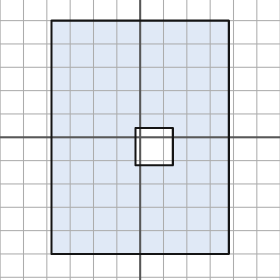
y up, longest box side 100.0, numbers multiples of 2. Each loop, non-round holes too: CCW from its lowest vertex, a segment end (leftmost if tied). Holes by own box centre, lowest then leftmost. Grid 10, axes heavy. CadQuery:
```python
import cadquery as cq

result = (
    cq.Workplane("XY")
    .moveTo(-38.0, -50.0)
    .lineTo(38.0, -50.0)
    .lineTo(38.0, 50.0)
    .lineTo(-38.0, 50.0)
    .close()
    .moveTo(-2.0, -12.0)
    .lineTo(14.0, -12.0)
    .lineTo(14.0, 4.0)
    .lineTo(-2.0, 4.0)
    .close()
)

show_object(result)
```